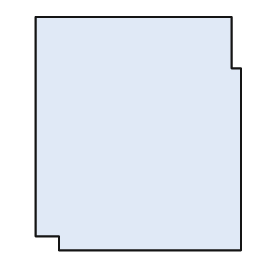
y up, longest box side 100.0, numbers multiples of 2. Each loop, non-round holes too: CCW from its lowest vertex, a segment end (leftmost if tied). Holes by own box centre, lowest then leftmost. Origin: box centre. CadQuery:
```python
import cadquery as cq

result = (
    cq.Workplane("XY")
    .moveTo(-34.0, -50.0)
    .lineTo(44.0, -50.0)
    .lineTo(44.0, 28.0)
    .lineTo(40.0, 28.0)
    .lineTo(40.0, 50.0)
    .lineTo(-44.0, 50.0)
    .lineTo(-44.0, -44.0)
    .lineTo(-34.0, -44.0)
    .close()
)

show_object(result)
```